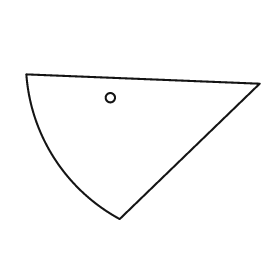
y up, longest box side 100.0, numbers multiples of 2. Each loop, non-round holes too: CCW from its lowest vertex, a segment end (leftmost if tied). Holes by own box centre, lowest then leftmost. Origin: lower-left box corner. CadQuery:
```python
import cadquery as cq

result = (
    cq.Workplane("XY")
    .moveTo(40.0, 0.0)
    .lineTo(100.0, 58.0)
    .lineTo(0.0, 62.0)
    .threePointArc((12.0, 26.0), (40.0, 0.0))
    .close()
    .moveTo(36.0, 52.0)
    .circle(2.0)
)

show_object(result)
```